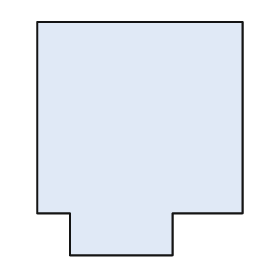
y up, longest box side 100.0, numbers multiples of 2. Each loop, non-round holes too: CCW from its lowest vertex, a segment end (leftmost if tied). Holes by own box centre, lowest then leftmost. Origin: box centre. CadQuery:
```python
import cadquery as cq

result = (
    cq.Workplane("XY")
    .moveTo(-30.0, -50.0)
    .lineTo(14.0, -50.0)
    .lineTo(14.0, -32.0)
    .lineTo(44.0, -32.0)
    .lineTo(44.0, 50.0)
    .lineTo(-44.0, 50.0)
    .lineTo(-44.0, -32.0)
    .lineTo(-30.0, -32.0)
    .close()
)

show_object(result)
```